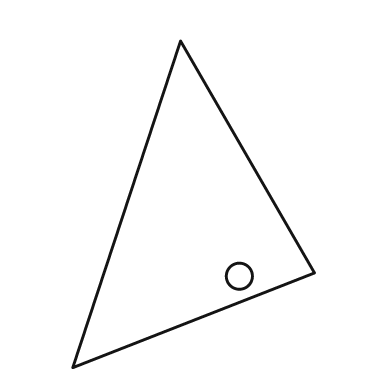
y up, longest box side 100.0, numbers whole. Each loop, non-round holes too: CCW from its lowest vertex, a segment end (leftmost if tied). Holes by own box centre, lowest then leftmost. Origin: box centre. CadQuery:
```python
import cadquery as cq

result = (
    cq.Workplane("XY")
    .moveTo(-37.0, -50.0)
    .lineTo(37.0, -21.0)
    .lineTo(-4.0, 50.0)
    .close()
    .moveTo(14.0, -22.0)
    .circle(4.0)
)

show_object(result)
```